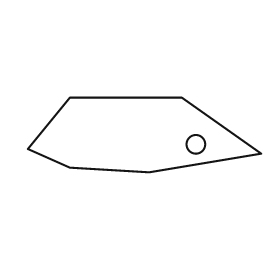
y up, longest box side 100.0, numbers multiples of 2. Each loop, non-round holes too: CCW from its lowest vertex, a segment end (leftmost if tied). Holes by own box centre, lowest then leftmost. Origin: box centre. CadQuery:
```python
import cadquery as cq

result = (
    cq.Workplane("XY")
    .moveTo(2.0, -16.0)
    .lineTo(50.0, -8.0)
    .lineTo(16.0, 16.0)
    .lineTo(-32.0, 16.0)
    .lineTo(-50.0, -6.0)
    .lineTo(-32.0, -14.0)
    .close()
    .moveTo(22.0, -4.0)
    .circle(4.0)
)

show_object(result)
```